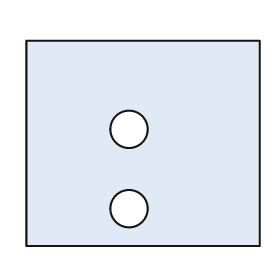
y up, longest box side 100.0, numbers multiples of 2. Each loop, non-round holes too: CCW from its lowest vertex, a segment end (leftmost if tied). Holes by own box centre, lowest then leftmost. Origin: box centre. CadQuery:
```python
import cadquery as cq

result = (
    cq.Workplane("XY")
    .moveTo(-50.0, -44.0)
    .lineTo(50.0, -44.0)
    .lineTo(50.0, 44.0)
    .lineTo(-50.0, 44.0)
    .close()
    .moveTo(-6.0, -28.0)
    .circle(8.0)
    .moveTo(-6.0, 6.0)
    .circle(8.0)
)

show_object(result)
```